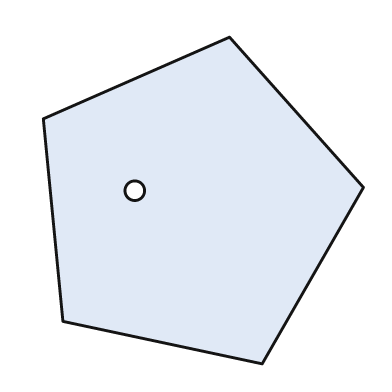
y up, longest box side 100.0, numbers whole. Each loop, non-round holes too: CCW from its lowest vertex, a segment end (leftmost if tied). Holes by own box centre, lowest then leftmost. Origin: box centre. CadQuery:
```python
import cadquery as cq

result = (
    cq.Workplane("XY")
    .moveTo(18.0, -50.0)
    .lineTo(49.0, 4.0)
    .lineTo(8.0, 50.0)
    .lineTo(-49.0, 25.0)
    .lineTo(-43.0, -37.0)
    .close()
    .moveTo(-21.0, 3.0)
    .circle(3.0)
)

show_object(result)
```